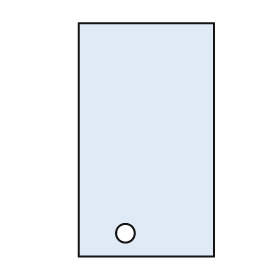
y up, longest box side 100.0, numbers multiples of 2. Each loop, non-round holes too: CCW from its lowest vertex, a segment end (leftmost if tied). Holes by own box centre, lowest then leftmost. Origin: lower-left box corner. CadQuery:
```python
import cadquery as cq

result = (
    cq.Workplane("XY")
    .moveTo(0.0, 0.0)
    .lineTo(58.0, 0.0)
    .lineTo(58.0, 100.0)
    .lineTo(0.0, 100.0)
    .close()
    .moveTo(20.0, 10.0)
    .circle(4.0)
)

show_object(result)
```